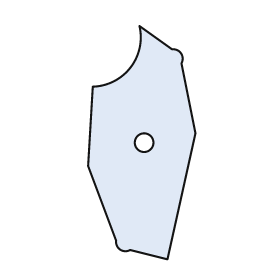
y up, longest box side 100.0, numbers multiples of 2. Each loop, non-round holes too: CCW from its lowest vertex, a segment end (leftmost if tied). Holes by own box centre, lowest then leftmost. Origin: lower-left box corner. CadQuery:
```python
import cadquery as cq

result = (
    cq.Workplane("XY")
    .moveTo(34.0, 0.0)
    .lineTo(46.0, 54.0)
    .lineTo(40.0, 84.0)
    .threePointArc((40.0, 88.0), (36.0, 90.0))
    .lineTo(22.0, 100.0)
    .threePointArc((18.0, 82.0), (2.0, 74.0))
    .lineTo(0.0, 40.0)
    .lineTo(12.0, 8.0)
    .threePointArc((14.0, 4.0), (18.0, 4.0))
    .close()
    .moveTo(24.0, 50.0)
    .circle(4.0)
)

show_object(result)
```